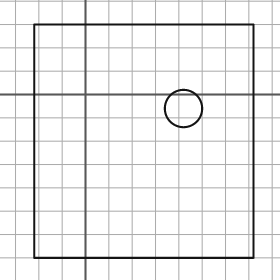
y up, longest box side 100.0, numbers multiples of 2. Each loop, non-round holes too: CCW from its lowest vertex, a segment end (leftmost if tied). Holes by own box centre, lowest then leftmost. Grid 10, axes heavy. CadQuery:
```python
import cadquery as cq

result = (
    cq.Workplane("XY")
    .moveTo(-22.0, -70.0)
    .lineTo(72.0, -70.0)
    .lineTo(72.0, 30.0)
    .lineTo(-22.0, 30.0)
    .close()
    .moveTo(42.0, -6.0)
    .circle(8.0)
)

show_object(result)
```